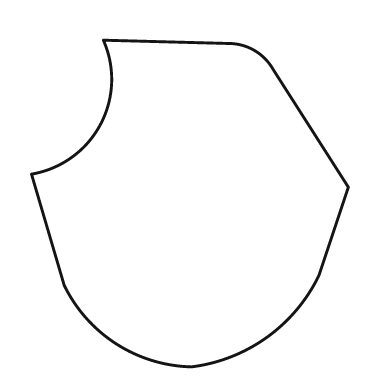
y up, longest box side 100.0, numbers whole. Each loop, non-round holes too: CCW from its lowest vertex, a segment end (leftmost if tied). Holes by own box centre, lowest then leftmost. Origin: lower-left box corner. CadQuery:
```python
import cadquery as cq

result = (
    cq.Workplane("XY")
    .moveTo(49.0, 0.0)
    .threePointArc((72.0, 9.0), (88.0, 28.0))
    .lineTo(97.0, 55.0)
    .lineTo(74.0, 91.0)
    .threePointArc((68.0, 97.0), (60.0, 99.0))
    .lineTo(22.0, 100.0)
    .threePointArc((21.0, 74.0), (0.0, 59.0))
    .lineTo(10.0, 25.0)
    .threePointArc((26.0, 7.0), (49.0, 0.0))
    .close()
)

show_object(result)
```